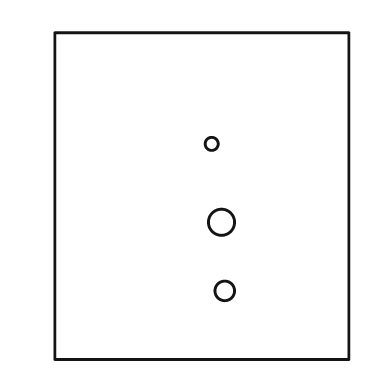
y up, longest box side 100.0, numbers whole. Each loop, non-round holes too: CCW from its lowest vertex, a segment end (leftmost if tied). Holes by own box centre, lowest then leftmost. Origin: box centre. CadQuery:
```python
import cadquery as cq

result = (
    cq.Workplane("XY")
    .moveTo(-45.0, -50.0)
    .lineTo(45.0, -50.0)
    .lineTo(45.0, 50.0)
    .lineTo(-45.0, 50.0)
    .close()
    .moveTo(7.0, -29.0)
    .circle(3.0)
    .moveTo(6.0, -8.0)
    .circle(4.0)
    .moveTo(3.0, 16.0)
    .circle(2.0)
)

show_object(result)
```